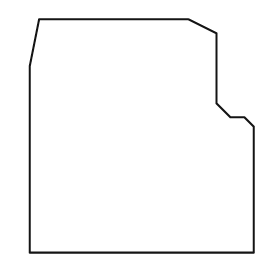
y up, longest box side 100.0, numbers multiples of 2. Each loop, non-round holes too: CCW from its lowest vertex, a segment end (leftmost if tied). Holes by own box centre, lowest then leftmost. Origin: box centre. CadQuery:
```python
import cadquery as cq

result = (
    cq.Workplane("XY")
    .moveTo(-48.0, -50.0)
    .lineTo(48.0, -50.0)
    .lineTo(48.0, 4.0)
    .lineTo(44.0, 8.0)
    .lineTo(38.0, 8.0)
    .lineTo(32.0, 14.0)
    .lineTo(32.0, 44.0)
    .lineTo(20.0, 50.0)
    .lineTo(-44.0, 50.0)
    .lineTo(-48.0, 30.0)
    .close()
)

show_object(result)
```